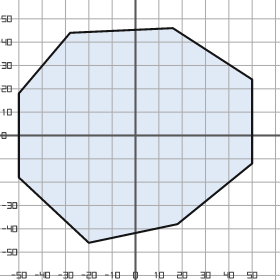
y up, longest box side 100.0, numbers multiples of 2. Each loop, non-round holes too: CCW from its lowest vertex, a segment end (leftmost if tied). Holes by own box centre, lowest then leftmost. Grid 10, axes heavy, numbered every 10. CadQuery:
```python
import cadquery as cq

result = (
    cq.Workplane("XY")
    .moveTo(-20.0, -46.0)
    .lineTo(18.0, -38.0)
    .lineTo(50.0, -12.0)
    .lineTo(50.0, 24.0)
    .lineTo(16.0, 46.0)
    .lineTo(-28.0, 44.0)
    .lineTo(-50.0, 18.0)
    .lineTo(-50.0, -18.0)
    .close()
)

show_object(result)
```